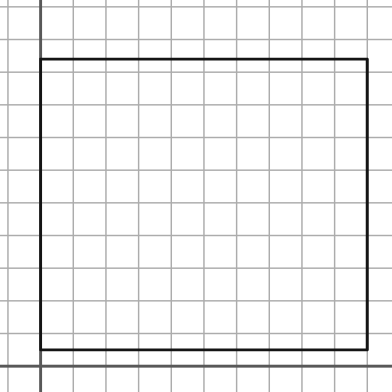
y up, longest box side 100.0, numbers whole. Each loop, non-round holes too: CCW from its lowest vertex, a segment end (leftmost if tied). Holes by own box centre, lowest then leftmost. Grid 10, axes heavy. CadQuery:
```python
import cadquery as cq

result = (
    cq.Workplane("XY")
    .moveTo(0.0, 5.0)
    .lineTo(100.0, 5.0)
    .lineTo(100.0, 94.0)
    .lineTo(0.0, 94.0)
    .close()
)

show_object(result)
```